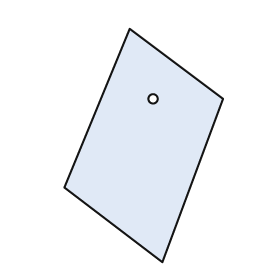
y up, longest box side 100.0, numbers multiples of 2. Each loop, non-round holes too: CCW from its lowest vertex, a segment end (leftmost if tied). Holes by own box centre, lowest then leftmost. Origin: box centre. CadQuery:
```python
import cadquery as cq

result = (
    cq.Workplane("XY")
    .moveTo(8.0, -50.0)
    .lineTo(34.0, 20.0)
    .lineTo(-6.0, 50.0)
    .lineTo(-34.0, -18.0)
    .close()
    .moveTo(4.0, 20.0)
    .circle(2.0)
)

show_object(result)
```